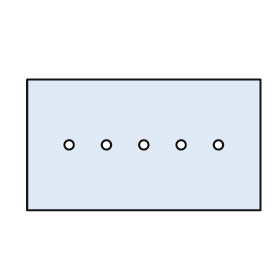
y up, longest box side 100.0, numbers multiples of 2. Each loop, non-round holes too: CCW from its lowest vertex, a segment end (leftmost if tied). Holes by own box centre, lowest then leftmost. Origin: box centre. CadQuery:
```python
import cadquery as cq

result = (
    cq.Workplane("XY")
    .moveTo(-50.0, -28.0)
    .lineTo(50.0, -28.0)
    .lineTo(50.0, 28.0)
    .lineTo(-50.0, 28.0)
    .close()
    .moveTo(-32.0, 0.0)
    .circle(2.0)
    .moveTo(-16.0, 0.0)
    .circle(2.0)
    .moveTo(0.0, 0.0)
    .circle(2.0)
    .moveTo(16.0, 0.0)
    .circle(2.0)
    .moveTo(32.0, 0.0)
    .circle(2.0)
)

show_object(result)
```